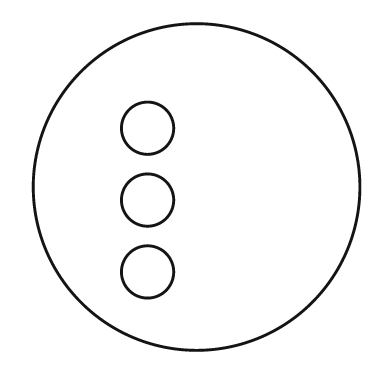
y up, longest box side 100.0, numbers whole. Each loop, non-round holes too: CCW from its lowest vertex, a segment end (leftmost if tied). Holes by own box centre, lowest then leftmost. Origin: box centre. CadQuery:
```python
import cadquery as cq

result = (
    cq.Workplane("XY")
    .moveTo(0.0, 0.0)
    .circle(50.0)
    .moveTo(-15.0, -26.0)
    .circle(8.0)
    .moveTo(-15.0, -4.0)
    .circle(8.0)
    .moveTo(-15.0, 18.0)
    .circle(8.0)
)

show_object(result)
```